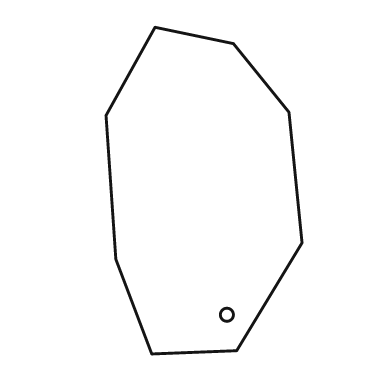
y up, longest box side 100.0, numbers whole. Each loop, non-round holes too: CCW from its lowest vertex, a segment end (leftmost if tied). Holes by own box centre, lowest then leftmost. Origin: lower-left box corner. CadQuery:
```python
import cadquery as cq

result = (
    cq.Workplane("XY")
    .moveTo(14.0, 0.0)
    .lineTo(40.0, 1.0)
    .lineTo(60.0, 34.0)
    .lineTo(56.0, 74.0)
    .lineTo(39.0, 95.0)
    .lineTo(15.0, 100.0)
    .lineTo(0.0, 73.0)
    .lineTo(3.0, 29.0)
    .close()
    .moveTo(37.0, 12.0)
    .circle(2.0)
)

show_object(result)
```